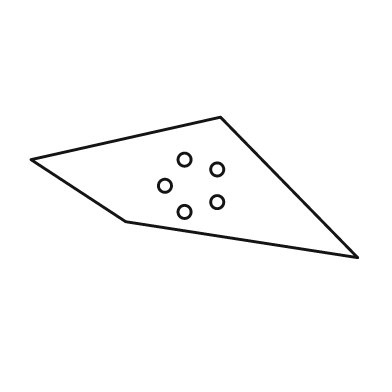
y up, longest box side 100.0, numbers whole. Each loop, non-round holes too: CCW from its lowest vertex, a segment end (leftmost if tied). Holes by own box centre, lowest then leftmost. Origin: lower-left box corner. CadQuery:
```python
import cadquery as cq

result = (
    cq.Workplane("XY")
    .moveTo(100.0, 0.0)
    .lineTo(58.0, 43.0)
    .lineTo(0.0, 30.0)
    .lineTo(29.0, 11.0)
    .close()
    .moveTo(47.0, 14.0)
    .circle(2.0)
    .moveTo(57.0, 17.0)
    .circle(2.0)
    .moveTo(41.0, 22.0)
    .circle(2.0)
    .moveTo(57.0, 27.0)
    .circle(2.0)
    .moveTo(47.0, 30.0)
    .circle(2.0)
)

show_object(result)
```